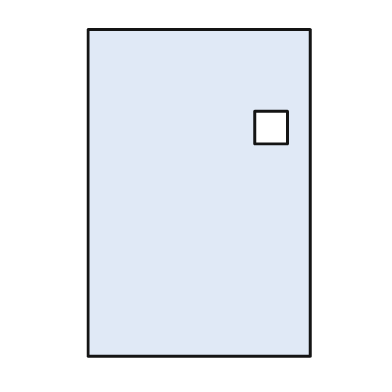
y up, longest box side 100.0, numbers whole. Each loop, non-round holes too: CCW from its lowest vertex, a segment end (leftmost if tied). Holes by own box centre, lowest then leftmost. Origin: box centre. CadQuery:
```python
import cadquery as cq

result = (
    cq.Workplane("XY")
    .moveTo(-34.0, -50.0)
    .lineTo(34.0, -50.0)
    .lineTo(34.0, 50.0)
    .lineTo(-34.0, 50.0)
    .close()
    .moveTo(17.0, 15.0)
    .lineTo(27.0, 15.0)
    .lineTo(27.0, 25.0)
    .lineTo(17.0, 25.0)
    .close()
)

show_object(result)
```